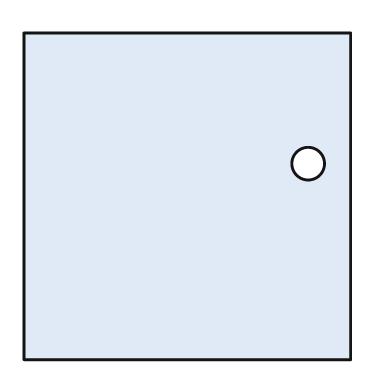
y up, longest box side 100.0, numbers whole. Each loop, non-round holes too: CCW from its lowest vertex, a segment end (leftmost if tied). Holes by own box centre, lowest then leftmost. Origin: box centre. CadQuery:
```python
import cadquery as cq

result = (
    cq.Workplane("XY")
    .moveTo(-50.0, -50.0)
    .lineTo(50.0, -50.0)
    .lineTo(50.0, 50.0)
    .lineTo(-50.0, 50.0)
    .close()
    .moveTo(37.0, 10.0)
    .circle(5.0)
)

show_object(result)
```